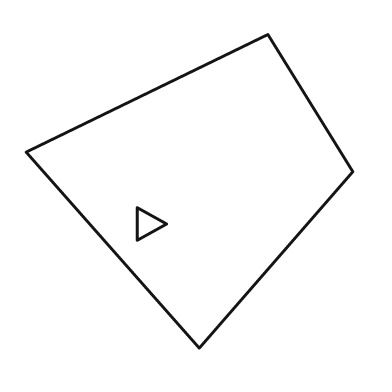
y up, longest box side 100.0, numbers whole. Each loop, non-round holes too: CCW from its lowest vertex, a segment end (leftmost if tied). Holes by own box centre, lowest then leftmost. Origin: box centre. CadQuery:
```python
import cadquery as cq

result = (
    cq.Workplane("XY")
    .moveTo(3.0, -48.0)
    .lineTo(50.0, 6.0)
    .lineTo(24.0, 48.0)
    .lineTo(-50.0, 12.0)
    .close()
    .moveTo(-16.0, -15.0)
    .lineTo(-7.0, -10.0)
    .lineTo(-16.0, -5.0)
    .close()
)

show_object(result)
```